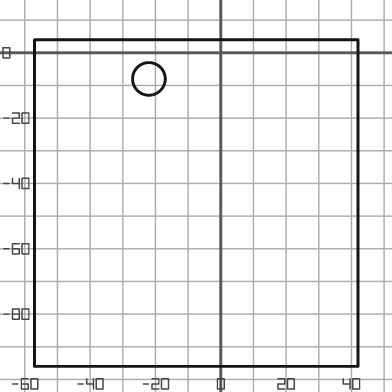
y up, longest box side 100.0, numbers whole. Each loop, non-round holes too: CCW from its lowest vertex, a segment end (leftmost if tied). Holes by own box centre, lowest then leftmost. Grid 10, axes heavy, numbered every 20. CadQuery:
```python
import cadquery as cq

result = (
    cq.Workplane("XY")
    .moveTo(-57.0, -96.0)
    .lineTo(42.0, -96.0)
    .lineTo(42.0, 4.0)
    .lineTo(-57.0, 4.0)
    .close()
    .moveTo(-22.0, -8.0)
    .circle(5.0)
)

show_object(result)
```